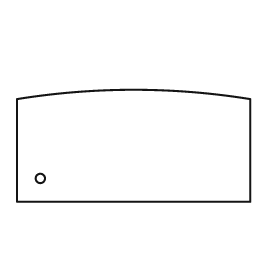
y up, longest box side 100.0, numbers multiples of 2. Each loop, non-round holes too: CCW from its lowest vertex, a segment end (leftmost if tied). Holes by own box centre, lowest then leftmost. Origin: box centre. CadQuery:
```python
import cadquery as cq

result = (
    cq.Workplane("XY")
    .moveTo(-50.0, -24.0)
    .lineTo(50.0, -24.0)
    .lineTo(50.0, 20.0)
    .threePointArc((0.0, 24.0), (-50.0, 20.0))
    .close()
    .moveTo(-40.0, -14.0)
    .circle(2.0)
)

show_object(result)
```